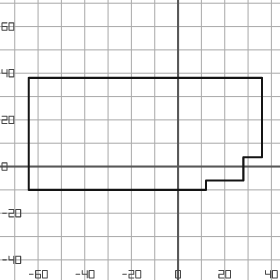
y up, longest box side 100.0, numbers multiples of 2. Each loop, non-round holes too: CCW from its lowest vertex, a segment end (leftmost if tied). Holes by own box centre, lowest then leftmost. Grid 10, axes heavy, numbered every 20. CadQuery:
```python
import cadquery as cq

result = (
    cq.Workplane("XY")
    .moveTo(-64.0, -10.0)
    .lineTo(12.0, -10.0)
    .lineTo(12.0, -6.0)
    .lineTo(28.0, -6.0)
    .lineTo(28.0, 4.0)
    .lineTo(36.0, 4.0)
    .lineTo(36.0, 38.0)
    .lineTo(-64.0, 38.0)
    .close()
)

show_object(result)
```